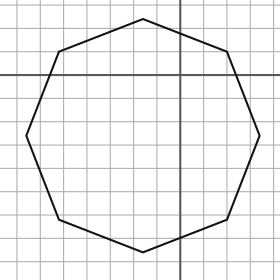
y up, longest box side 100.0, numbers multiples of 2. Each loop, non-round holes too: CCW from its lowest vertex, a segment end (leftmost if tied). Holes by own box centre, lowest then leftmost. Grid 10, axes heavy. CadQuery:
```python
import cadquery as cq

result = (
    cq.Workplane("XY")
    .moveTo(-16.0, -76.0)
    .lineTo(20.0, -62.0)
    .lineTo(34.0, -26.0)
    .lineTo(20.0, 10.0)
    .lineTo(-16.0, 24.0)
    .lineTo(-52.0, 10.0)
    .lineTo(-66.0, -26.0)
    .lineTo(-52.0, -62.0)
    .close()
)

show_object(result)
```